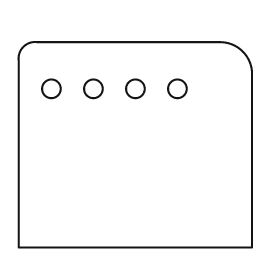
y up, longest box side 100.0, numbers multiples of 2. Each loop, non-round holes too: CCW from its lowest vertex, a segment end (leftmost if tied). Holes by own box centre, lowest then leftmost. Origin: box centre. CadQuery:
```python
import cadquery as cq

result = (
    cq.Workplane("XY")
    .moveTo(-50.0, -44.0)
    .lineTo(50.0, -44.0)
    .lineTo(50.0, 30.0)
    .threePointArc((46.0, 40.0), (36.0, 44.0))
    .lineTo(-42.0, 44.0)
    .threePointArc((-48.0, 42.0), (-50.0, 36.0))
    .close()
    .moveTo(-36.0, 24.0)
    .circle(4.0)
    .moveTo(-18.0, 24.0)
    .circle(4.0)
    .moveTo(0.0, 24.0)
    .circle(4.0)
    .moveTo(18.0, 24.0)
    .circle(4.0)
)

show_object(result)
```